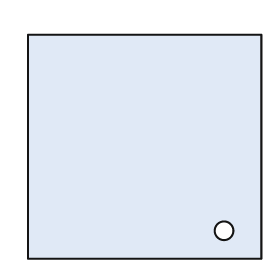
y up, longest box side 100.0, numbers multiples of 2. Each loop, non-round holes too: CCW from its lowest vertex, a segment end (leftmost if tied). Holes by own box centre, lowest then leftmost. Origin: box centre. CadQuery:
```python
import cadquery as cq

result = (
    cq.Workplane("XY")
    .moveTo(-50.0, -48.0)
    .lineTo(50.0, -48.0)
    .lineTo(50.0, 48.0)
    .lineTo(-50.0, 48.0)
    .close()
    .moveTo(34.0, -36.0)
    .circle(4.0)
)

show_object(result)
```